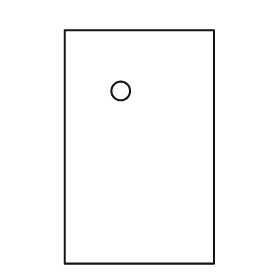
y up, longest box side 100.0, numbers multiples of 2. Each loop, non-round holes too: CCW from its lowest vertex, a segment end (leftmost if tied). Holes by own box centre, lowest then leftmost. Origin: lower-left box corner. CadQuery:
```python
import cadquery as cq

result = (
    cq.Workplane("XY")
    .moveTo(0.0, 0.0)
    .lineTo(64.0, 0.0)
    .lineTo(64.0, 100.0)
    .lineTo(0.0, 100.0)
    .close()
    .moveTo(24.0, 74.0)
    .circle(4.0)
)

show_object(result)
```